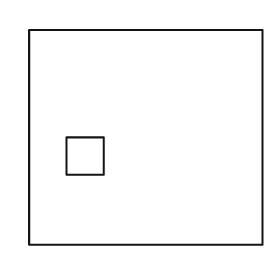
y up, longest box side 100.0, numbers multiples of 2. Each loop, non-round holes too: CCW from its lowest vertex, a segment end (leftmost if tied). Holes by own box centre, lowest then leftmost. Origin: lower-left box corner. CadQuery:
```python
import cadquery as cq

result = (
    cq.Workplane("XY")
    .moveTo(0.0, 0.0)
    .lineTo(100.0, 0.0)
    .lineTo(100.0, 92.0)
    .lineTo(0.0, 92.0)
    .close()
    .moveTo(16.0, 30.0)
    .lineTo(32.0, 30.0)
    .lineTo(32.0, 46.0)
    .lineTo(16.0, 46.0)
    .close()
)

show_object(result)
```